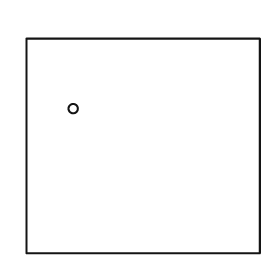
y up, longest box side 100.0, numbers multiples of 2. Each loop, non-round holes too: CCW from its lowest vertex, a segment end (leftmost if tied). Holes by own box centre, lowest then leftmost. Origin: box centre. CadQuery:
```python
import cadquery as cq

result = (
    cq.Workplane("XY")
    .moveTo(-50.0, -46.0)
    .lineTo(50.0, -46.0)
    .lineTo(50.0, 46.0)
    .lineTo(-50.0, 46.0)
    .close()
    .moveTo(-30.0, 16.0)
    .circle(2.0)
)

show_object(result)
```